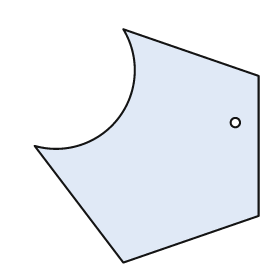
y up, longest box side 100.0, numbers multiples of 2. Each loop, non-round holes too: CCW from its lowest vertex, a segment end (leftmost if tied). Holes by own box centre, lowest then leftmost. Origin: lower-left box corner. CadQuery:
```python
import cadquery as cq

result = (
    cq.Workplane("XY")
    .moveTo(38.0, 0.0)
    .lineTo(96.0, 20.0)
    .lineTo(96.0, 80.0)
    .lineTo(38.0, 100.0)
    .threePointArc((36.0, 62.0), (0.0, 50.0))
    .close()
    .moveTo(86.0, 60.0)
    .circle(2.0)
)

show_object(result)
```